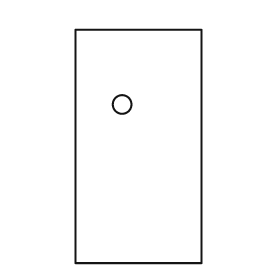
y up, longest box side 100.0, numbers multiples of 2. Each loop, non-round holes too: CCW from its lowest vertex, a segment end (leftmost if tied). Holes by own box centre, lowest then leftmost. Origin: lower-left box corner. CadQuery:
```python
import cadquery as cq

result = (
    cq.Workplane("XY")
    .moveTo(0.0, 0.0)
    .lineTo(54.0, 0.0)
    .lineTo(54.0, 100.0)
    .lineTo(0.0, 100.0)
    .close()
    .moveTo(20.0, 68.0)
    .circle(4.0)
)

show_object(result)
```